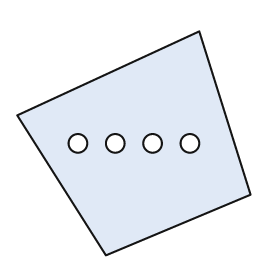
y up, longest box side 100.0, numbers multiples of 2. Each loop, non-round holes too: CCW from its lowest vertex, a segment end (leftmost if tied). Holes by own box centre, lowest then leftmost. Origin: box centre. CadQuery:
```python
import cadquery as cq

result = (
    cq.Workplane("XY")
    .moveTo(-12.0, -48.0)
    .lineTo(50.0, -22.0)
    .lineTo(28.0, 48.0)
    .lineTo(-50.0, 12.0)
    .close()
    .moveTo(-24.0, 0.0)
    .circle(4.0)
    .moveTo(-8.0, 0.0)
    .circle(4.0)
    .moveTo(8.0, 0.0)
    .circle(4.0)
    .moveTo(24.0, 0.0)
    .circle(4.0)
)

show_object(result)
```